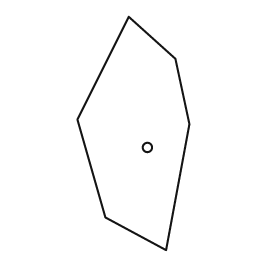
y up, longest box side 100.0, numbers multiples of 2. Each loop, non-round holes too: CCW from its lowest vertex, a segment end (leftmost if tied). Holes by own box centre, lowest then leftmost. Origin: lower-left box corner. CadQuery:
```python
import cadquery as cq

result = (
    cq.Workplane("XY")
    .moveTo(38.0, 0.0)
    .lineTo(48.0, 54.0)
    .lineTo(42.0, 82.0)
    .lineTo(22.0, 100.0)
    .lineTo(0.0, 56.0)
    .lineTo(12.0, 14.0)
    .close()
    .moveTo(30.0, 44.0)
    .circle(2.0)
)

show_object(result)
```